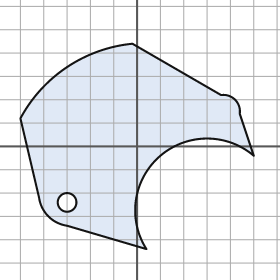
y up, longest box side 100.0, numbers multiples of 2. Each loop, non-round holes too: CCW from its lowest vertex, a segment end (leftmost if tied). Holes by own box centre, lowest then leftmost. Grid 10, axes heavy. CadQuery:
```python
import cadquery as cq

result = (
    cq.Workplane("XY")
    .moveTo(4.0, -44.0)
    .threePointArc((10.0, -4.0), (50.0, -4.0))
    .lineTo(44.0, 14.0)
    .threePointArc((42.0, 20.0), (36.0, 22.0))
    .lineTo(-2.0, 44.0)
    .threePointArc((-30.0, 34.0), (-50.0, 12.0))
    .lineTo(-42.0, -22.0)
    .threePointArc((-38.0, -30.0), (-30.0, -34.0))
    .close()
    .moveTo(-30.0, -24.0)
    .circle(4.0)
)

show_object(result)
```